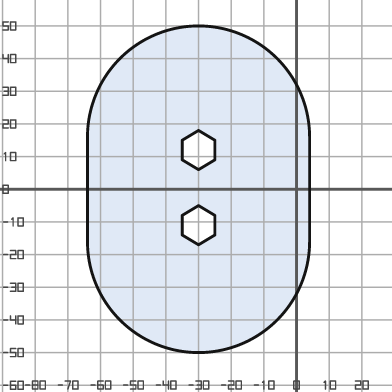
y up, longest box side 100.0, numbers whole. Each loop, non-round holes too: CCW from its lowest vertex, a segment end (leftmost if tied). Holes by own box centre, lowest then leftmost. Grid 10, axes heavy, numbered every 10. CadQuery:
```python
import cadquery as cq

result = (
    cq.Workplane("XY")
    .moveTo(-64.0, -16.0)
    .threePointArc((-30.0, -50.0), (4.0, -16.0))
    .lineTo(4.0, 16.0)
    .threePointArc((-30.0, 50.0), (-64.0, 16.0))
    .close()
    .moveTo(-30.0, -17.0)
    .lineTo(-25.0, -14.0)
    .lineTo(-25.0, -8.0)
    .lineTo(-30.0, -5.0)
    .lineTo(-35.0, -8.0)
    .lineTo(-35.0, -14.0)
    .close()
    .moveTo(-30.0, 6.0)
    .lineTo(-25.0, 9.0)
    .lineTo(-25.0, 15.0)
    .lineTo(-30.0, 18.0)
    .lineTo(-35.0, 15.0)
    .lineTo(-35.0, 9.0)
    .close()
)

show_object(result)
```